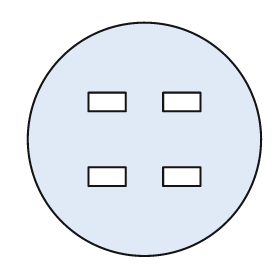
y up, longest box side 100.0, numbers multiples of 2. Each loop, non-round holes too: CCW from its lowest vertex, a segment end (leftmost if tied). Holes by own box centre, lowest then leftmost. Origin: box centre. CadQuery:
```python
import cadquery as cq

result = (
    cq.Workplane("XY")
    .moveTo(0.0, 0.0)
    .circle(50.0)
    .moveTo(-24.0, -20.0)
    .lineTo(-8.0, -20.0)
    .lineTo(-8.0, -12.0)
    .lineTo(-24.0, -12.0)
    .close()
    .moveTo(8.0, -20.0)
    .lineTo(24.0, -20.0)
    .lineTo(24.0, -12.0)
    .lineTo(8.0, -12.0)
    .close()
    .moveTo(-24.0, 12.0)
    .lineTo(-8.0, 12.0)
    .lineTo(-8.0, 20.0)
    .lineTo(-24.0, 20.0)
    .close()
    .moveTo(8.0, 12.0)
    .lineTo(24.0, 12.0)
    .lineTo(24.0, 20.0)
    .lineTo(8.0, 20.0)
    .close()
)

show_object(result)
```